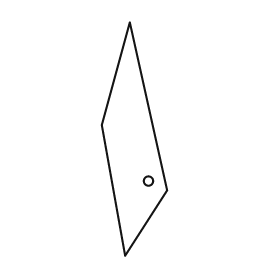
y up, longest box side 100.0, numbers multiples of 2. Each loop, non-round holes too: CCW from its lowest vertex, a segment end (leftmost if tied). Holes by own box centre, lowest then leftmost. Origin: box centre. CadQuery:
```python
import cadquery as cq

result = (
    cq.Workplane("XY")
    .moveTo(-4.0, -50.0)
    .lineTo(14.0, -22.0)
    .lineTo(-2.0, 50.0)
    .lineTo(-14.0, 6.0)
    .close()
    .moveTo(6.0, -18.0)
    .circle(2.0)
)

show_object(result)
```